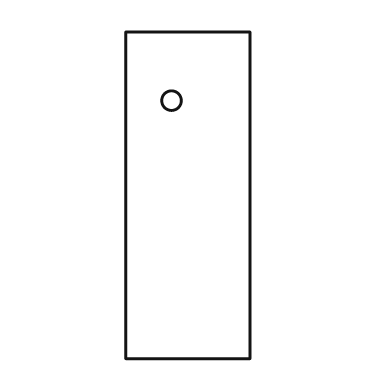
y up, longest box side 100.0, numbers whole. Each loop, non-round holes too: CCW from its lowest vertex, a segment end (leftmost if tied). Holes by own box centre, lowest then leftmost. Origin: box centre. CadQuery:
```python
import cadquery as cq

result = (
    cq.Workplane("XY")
    .moveTo(-19.0, -50.0)
    .lineTo(19.0, -50.0)
    .lineTo(19.0, 50.0)
    .lineTo(-19.0, 50.0)
    .close()
    .moveTo(-5.0, 29.0)
    .circle(3.0)
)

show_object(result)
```